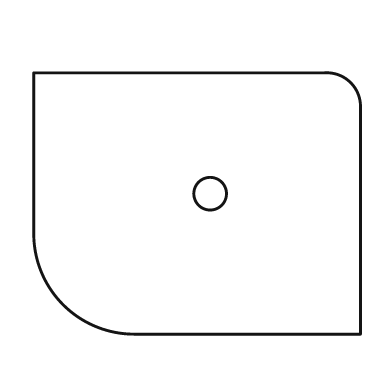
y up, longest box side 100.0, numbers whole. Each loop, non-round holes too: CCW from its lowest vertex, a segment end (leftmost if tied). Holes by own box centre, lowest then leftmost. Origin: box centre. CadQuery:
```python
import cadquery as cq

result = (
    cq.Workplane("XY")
    .moveTo(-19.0, -40.0)
    .lineTo(50.0, -40.0)
    .lineTo(50.0, 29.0)
    .threePointArc((47.0, 37.0), (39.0, 40.0))
    .lineTo(-50.0, 40.0)
    .lineTo(-50.0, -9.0)
    .threePointArc((-41.0, -31.0), (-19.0, -40.0))
    .close()
    .moveTo(4.0, 3.0)
    .circle(5.0)
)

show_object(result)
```